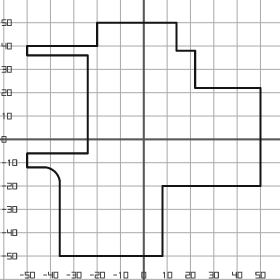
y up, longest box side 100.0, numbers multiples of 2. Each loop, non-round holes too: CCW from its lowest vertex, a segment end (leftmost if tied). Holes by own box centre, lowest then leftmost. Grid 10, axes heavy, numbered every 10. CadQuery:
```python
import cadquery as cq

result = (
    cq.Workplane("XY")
    .moveTo(-36.0, -50.0)
    .lineTo(8.0, -50.0)
    .lineTo(8.0, -20.0)
    .lineTo(50.0, -20.0)
    .lineTo(50.0, 22.0)
    .lineTo(22.0, 22.0)
    .lineTo(22.0, 38.0)
    .lineTo(14.0, 38.0)
    .lineTo(14.0, 50.0)
    .lineTo(-20.0, 50.0)
    .lineTo(-20.0, 40.0)
    .lineTo(-50.0, 40.0)
    .lineTo(-50.0, 36.0)
    .lineTo(-24.0, 36.0)
    .lineTo(-24.0, -6.0)
    .lineTo(-50.0, -6.0)
    .lineTo(-50.0, -12.0)
    .lineTo(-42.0, -12.0)
    .threePointArc((-38.0, -14.0), (-36.0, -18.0))
    .close()
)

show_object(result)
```